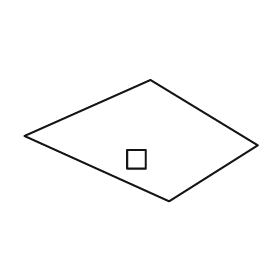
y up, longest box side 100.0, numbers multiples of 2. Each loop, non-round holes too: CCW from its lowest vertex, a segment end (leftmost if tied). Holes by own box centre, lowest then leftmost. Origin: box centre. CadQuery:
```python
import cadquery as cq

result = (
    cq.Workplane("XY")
    .moveTo(12.0, -26.0)
    .lineTo(50.0, -2.0)
    .lineTo(4.0, 26.0)
    .lineTo(-50.0, 2.0)
    .close()
    .moveTo(-6.0, -12.0)
    .lineTo(2.0, -12.0)
    .lineTo(2.0, -4.0)
    .lineTo(-6.0, -4.0)
    .close()
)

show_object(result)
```